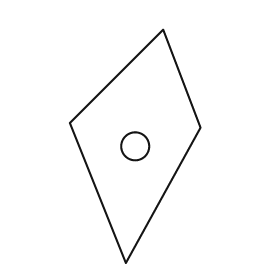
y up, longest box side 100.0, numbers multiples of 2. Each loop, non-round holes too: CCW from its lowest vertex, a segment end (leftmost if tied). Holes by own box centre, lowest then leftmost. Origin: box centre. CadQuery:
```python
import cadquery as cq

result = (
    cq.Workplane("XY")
    .moveTo(-4.0, -50.0)
    .lineTo(28.0, 8.0)
    .lineTo(12.0, 50.0)
    .lineTo(-28.0, 10.0)
    .close()
    .moveTo(0.0, 0.0)
    .circle(6.0)
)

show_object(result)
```